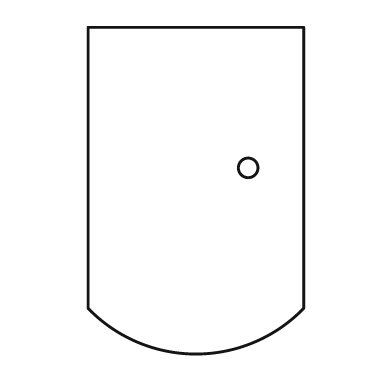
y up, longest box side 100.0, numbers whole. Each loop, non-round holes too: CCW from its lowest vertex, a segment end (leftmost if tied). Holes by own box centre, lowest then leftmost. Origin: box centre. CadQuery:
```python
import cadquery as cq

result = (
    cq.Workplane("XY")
    .moveTo(-33.0, -36.0)
    .threePointArc((0.0, -50.0), (33.0, -36.0))
    .lineTo(33.0, 50.0)
    .lineTo(-33.0, 50.0)
    .close()
    .moveTo(16.0, 7.0)
    .circle(3.0)
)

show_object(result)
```